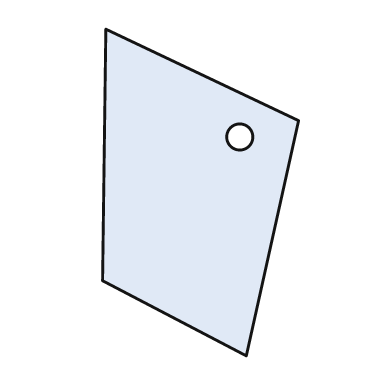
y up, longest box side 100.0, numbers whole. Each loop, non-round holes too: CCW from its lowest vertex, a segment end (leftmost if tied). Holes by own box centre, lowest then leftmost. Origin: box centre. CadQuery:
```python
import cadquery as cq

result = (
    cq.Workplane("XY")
    .moveTo(14.0, -50.0)
    .lineTo(30.0, 22.0)
    .lineTo(-29.0, 50.0)
    .lineTo(-30.0, -27.0)
    .close()
    .moveTo(12.0, 17.0)
    .circle(4.0)
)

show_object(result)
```